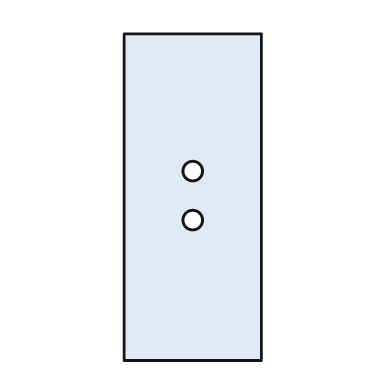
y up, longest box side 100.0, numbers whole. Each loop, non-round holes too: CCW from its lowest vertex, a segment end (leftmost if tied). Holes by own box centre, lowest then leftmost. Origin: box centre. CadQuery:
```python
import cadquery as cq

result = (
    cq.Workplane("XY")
    .moveTo(-21.0, -50.0)
    .lineTo(21.0, -50.0)
    .lineTo(21.0, 50.0)
    .lineTo(-21.0, 50.0)
    .close()
    .moveTo(0.0, -7.0)
    .circle(3.0)
    .moveTo(0.0, 8.0)
    .circle(3.0)
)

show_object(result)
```